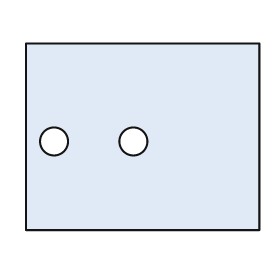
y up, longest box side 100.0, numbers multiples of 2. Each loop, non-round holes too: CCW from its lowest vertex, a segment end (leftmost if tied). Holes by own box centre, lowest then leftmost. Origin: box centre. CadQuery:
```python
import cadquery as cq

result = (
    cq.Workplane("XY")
    .moveTo(-50.0, -40.0)
    .lineTo(50.0, -40.0)
    .lineTo(50.0, 40.0)
    .lineTo(-50.0, 40.0)
    .close()
    .moveTo(-38.0, -2.0)
    .circle(6.0)
    .moveTo(-4.0, -2.0)
    .circle(6.0)
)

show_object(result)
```